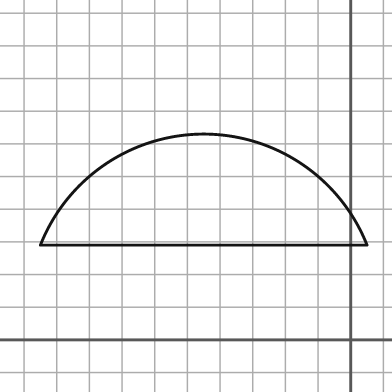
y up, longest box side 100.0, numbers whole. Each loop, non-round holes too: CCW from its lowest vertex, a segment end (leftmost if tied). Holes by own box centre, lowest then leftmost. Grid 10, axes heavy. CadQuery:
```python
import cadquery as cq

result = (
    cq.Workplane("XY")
    .moveTo(-95.0, 29.0)
    .lineTo(5.0, 29.0)
    .threePointArc((-45.0, 63.0), (-95.0, 29.0))
    .close()
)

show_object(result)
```